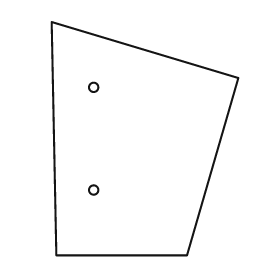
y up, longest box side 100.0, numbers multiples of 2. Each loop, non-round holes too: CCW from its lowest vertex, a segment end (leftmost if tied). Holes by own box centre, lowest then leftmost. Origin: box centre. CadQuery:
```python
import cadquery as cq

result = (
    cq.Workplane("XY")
    .moveTo(-38.0, -50.0)
    .lineTo(18.0, -50.0)
    .lineTo(40.0, 26.0)
    .lineTo(-40.0, 50.0)
    .close()
    .moveTo(-22.0, -22.0)
    .circle(2.0)
    .moveTo(-22.0, 22.0)
    .circle(2.0)
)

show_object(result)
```